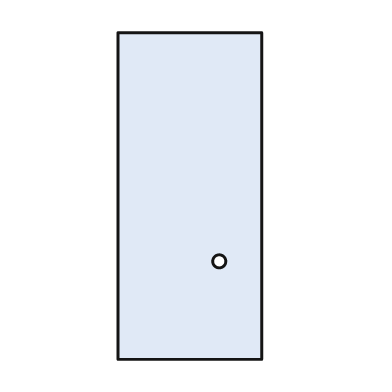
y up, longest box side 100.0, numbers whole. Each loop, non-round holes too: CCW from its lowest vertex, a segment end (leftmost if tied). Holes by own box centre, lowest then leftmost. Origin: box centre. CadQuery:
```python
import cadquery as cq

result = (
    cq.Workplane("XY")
    .moveTo(-22.0, -50.0)
    .lineTo(22.0, -50.0)
    .lineTo(22.0, 50.0)
    .lineTo(-22.0, 50.0)
    .close()
    .moveTo(9.0, -20.0)
    .circle(2.0)
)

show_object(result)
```